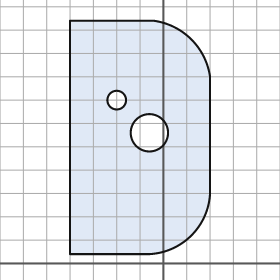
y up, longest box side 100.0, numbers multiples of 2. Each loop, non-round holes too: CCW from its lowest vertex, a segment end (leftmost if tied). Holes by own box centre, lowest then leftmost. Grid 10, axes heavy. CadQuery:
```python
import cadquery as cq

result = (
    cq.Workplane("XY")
    .moveTo(-40.0, 4.0)
    .lineTo(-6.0, 4.0)
    .threePointArc((12.0, 12.0), (20.0, 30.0))
    .lineTo(20.0, 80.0)
    .threePointArc((12.0, 96.0), (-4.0, 104.0))
    .lineTo(-40.0, 104.0)
    .close()
    .moveTo(-6.0, 56.0)
    .circle(8.0)
    .moveTo(-20.0, 70.0)
    .circle(4.0)
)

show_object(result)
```